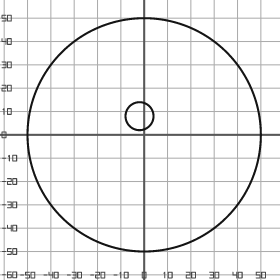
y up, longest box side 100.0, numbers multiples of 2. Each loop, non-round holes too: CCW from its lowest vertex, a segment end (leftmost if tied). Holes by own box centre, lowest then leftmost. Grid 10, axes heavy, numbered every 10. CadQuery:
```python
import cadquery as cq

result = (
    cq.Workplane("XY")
    .moveTo(0.0, 0.0)
    .circle(50.0)
    .moveTo(-2.0, 8.0)
    .circle(6.0)
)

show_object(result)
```